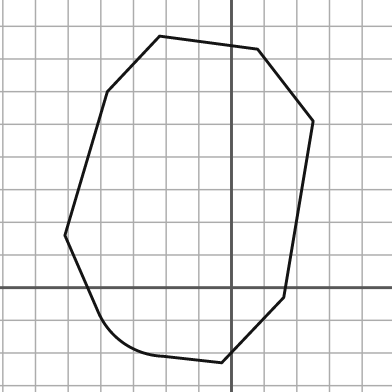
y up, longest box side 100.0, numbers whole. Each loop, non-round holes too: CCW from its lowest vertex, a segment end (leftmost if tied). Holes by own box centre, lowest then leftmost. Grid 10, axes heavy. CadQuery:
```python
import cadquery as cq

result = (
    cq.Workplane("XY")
    .moveTo(-3.0, -23.0)
    .lineTo(16.0, -3.0)
    .lineTo(25.0, 51.0)
    .lineTo(8.0, 73.0)
    .lineTo(-22.0, 77.0)
    .lineTo(-38.0, 60.0)
    .lineTo(-51.0, 16.0)
    .lineTo(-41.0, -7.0)
    .threePointArc((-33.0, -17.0), (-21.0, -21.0))
    .close()
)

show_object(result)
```